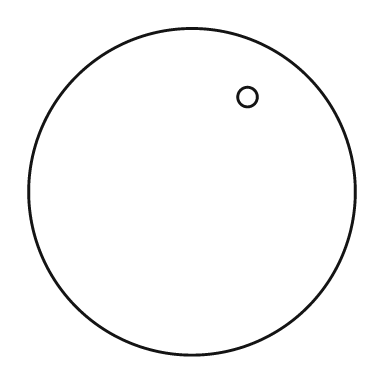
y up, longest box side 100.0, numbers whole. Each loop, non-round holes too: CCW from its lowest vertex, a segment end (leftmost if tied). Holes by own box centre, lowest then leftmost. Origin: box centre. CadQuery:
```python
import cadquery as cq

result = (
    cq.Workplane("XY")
    .moveTo(0.0, 0.0)
    .circle(50.0)
    .moveTo(17.0, 29.0)
    .circle(3.0)
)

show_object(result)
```